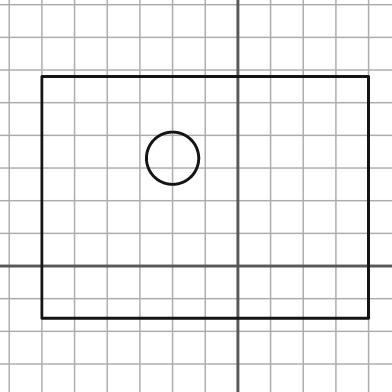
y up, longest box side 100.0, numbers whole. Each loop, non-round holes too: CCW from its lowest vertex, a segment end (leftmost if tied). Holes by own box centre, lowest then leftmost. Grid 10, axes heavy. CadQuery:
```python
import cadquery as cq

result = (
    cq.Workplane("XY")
    .moveTo(-60.0, -16.0)
    .lineTo(40.0, -16.0)
    .lineTo(40.0, 58.0)
    .lineTo(-60.0, 58.0)
    .close()
    .moveTo(-20.0, 33.0)
    .circle(8.0)
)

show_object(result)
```